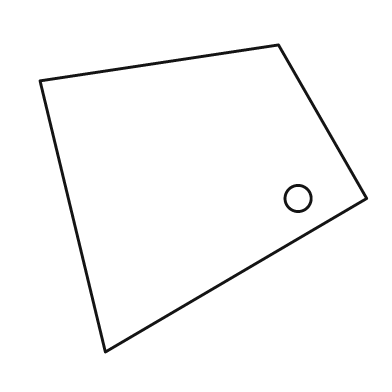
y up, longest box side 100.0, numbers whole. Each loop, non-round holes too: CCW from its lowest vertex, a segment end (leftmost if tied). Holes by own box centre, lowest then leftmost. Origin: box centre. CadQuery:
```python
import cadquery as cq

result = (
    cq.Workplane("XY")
    .moveTo(-30.0, -47.0)
    .lineTo(50.0, 0.0)
    .lineTo(23.0, 47.0)
    .lineTo(-50.0, 36.0)
    .close()
    .moveTo(29.0, 0.0)
    .circle(4.0)
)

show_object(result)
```